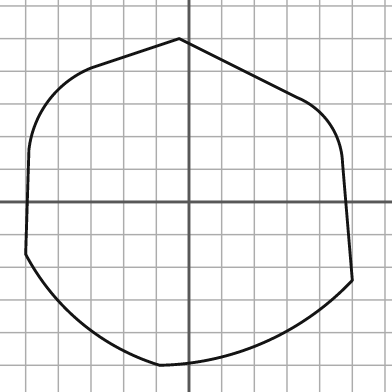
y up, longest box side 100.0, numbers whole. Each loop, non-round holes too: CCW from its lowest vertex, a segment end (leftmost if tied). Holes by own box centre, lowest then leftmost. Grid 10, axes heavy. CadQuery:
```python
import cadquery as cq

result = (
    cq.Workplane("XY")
    .moveTo(-9.0, -50.0)
    .threePointArc((23.0, -43.0), (50.0, -24.0))
    .lineTo(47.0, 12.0)
    .threePointArc((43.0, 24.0), (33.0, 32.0))
    .lineTo(-3.0, 50.0)
    .lineTo(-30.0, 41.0)
    .threePointArc((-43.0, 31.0), (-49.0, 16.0))
    .lineTo(-50.0, -16.0)
    .threePointArc((-33.0, -37.0), (-9.0, -50.0))
    .close()
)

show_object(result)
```